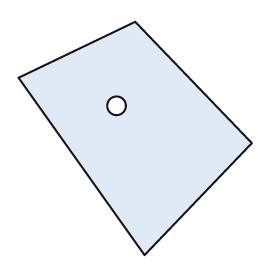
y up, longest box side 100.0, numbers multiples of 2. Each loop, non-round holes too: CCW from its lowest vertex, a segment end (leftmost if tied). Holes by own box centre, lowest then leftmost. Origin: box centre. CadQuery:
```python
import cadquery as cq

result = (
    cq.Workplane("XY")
    .moveTo(4.0, -50.0)
    .lineTo(50.0, -2.0)
    .lineTo(0.0, 50.0)
    .lineTo(-50.0, 26.0)
    .close()
    .moveTo(-8.0, 14.0)
    .circle(4.0)
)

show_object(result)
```